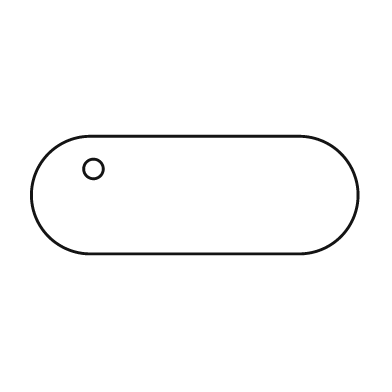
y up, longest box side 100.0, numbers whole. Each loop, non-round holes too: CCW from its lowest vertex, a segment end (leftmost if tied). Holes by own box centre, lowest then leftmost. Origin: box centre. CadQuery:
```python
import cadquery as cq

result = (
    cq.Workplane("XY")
    .moveTo(-32.0, -18.0)
    .lineTo(32.0, -18.0)
    .threePointArc((50.0, 0.0), (32.0, 18.0))
    .lineTo(-32.0, 18.0)
    .threePointArc((-50.0, 0.0), (-32.0, -18.0))
    .close()
    .moveTo(-31.0, 8.0)
    .circle(3.0)
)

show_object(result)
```